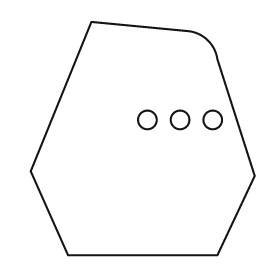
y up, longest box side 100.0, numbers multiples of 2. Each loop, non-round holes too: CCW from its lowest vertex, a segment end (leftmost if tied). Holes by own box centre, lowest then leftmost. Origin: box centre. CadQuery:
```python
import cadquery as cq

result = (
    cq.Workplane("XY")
    .moveTo(-32.0, -50.0)
    .lineTo(32.0, -50.0)
    .lineTo(48.0, -16.0)
    .lineTo(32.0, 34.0)
    .threePointArc((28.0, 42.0), (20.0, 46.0))
    .lineTo(-22.0, 50.0)
    .lineTo(-48.0, -14.0)
    .close()
    .moveTo(2.0, 8.0)
    .circle(4.0)
    .moveTo(16.0, 8.0)
    .circle(4.0)
    .moveTo(30.0, 8.0)
    .circle(4.0)
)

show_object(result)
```